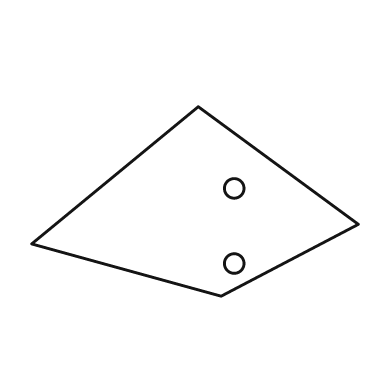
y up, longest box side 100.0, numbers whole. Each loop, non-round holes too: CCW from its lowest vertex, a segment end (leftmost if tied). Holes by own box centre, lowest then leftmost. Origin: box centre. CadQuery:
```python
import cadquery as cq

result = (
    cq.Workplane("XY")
    .moveTo(8.0, -29.0)
    .lineTo(50.0, -7.0)
    .lineTo(1.0, 29.0)
    .lineTo(-50.0, -13.0)
    .close()
    .moveTo(12.0, -19.0)
    .circle(3.0)
    .moveTo(12.0, 4.0)
    .circle(3.0)
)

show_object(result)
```